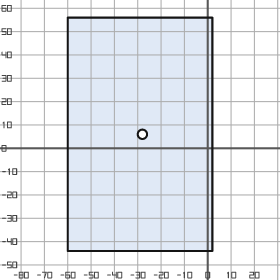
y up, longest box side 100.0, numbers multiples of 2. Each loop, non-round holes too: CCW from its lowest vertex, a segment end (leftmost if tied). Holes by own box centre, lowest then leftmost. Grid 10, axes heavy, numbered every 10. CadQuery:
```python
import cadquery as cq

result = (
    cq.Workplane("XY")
    .moveTo(-60.0, -44.0)
    .lineTo(2.0, -44.0)
    .lineTo(2.0, 56.0)
    .lineTo(-60.0, 56.0)
    .close()
    .moveTo(-28.0, 6.0)
    .circle(2.0)
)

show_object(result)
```